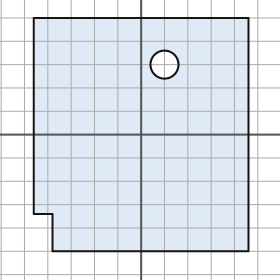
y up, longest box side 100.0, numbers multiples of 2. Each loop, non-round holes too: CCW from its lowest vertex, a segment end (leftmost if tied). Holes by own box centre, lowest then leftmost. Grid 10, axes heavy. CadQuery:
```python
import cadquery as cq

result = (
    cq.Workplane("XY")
    .moveTo(-38.0, -50.0)
    .lineTo(46.0, -50.0)
    .lineTo(46.0, 50.0)
    .lineTo(-46.0, 50.0)
    .lineTo(-46.0, -34.0)
    .lineTo(-38.0, -34.0)
    .close()
    .moveTo(10.0, 30.0)
    .circle(6.0)
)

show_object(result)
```